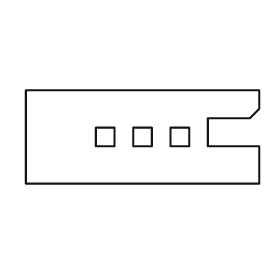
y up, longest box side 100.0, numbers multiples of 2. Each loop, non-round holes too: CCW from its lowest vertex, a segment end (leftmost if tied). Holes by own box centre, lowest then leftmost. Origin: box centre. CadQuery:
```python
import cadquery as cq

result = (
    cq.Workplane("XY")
    .moveTo(-50.0, -20.0)
    .lineTo(50.0, -20.0)
    .lineTo(50.0, -4.0)
    .lineTo(28.0, -4.0)
    .lineTo(28.0, 8.0)
    .lineTo(46.0, 8.0)
    .lineTo(50.0, 12.0)
    .lineTo(50.0, 20.0)
    .lineTo(-50.0, 20.0)
    .close()
    .moveTo(-20.0, -4.0)
    .lineTo(-12.0, -4.0)
    .lineTo(-12.0, 4.0)
    .lineTo(-20.0, 4.0)
    .close()
    .moveTo(-4.0, -4.0)
    .lineTo(4.0, -4.0)
    .lineTo(4.0, 4.0)
    .lineTo(-4.0, 4.0)
    .close()
    .moveTo(12.0, -4.0)
    .lineTo(20.0, -4.0)
    .lineTo(20.0, 4.0)
    .lineTo(12.0, 4.0)
    .close()
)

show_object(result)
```